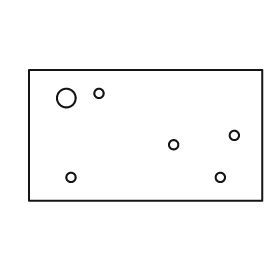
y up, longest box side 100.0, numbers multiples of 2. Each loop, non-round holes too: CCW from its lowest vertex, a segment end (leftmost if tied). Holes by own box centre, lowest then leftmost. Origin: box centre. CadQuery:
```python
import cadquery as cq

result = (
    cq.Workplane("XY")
    .moveTo(-50.0, -28.0)
    .lineTo(50.0, -28.0)
    .lineTo(50.0, 28.0)
    .lineTo(-50.0, 28.0)
    .close()
    .moveTo(-32.0, -18.0)
    .circle(2.0)
    .moveTo(32.0, -18.0)
    .circle(2.0)
    .moveTo(12.0, -4.0)
    .circle(2.0)
    .moveTo(38.0, 0.0)
    .circle(2.0)
    .moveTo(-34.0, 16.0)
    .circle(4.0)
    .moveTo(-20.0, 18.0)
    .circle(2.0)
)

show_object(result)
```